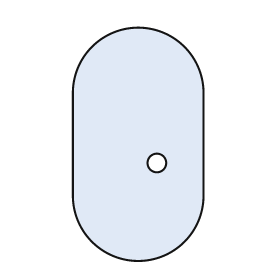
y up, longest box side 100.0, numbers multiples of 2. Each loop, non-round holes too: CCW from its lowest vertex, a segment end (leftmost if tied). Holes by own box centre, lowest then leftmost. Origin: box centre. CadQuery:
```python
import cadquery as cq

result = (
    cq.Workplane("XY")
    .moveTo(-28.0, -22.0)
    .threePointArc((0.0, -50.0), (28.0, -22.0))
    .lineTo(28.0, 22.0)
    .threePointArc((0.0, 50.0), (-28.0, 22.0))
    .close()
    .moveTo(8.0, -8.0)
    .circle(4.0)
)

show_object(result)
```